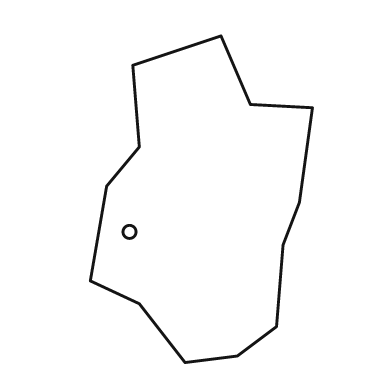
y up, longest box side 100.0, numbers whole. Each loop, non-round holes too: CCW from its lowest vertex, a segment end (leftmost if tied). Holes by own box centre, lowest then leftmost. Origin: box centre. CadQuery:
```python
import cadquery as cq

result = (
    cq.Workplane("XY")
    .moveTo(-5.0, -50.0)
    .lineTo(11.0, -48.0)
    .lineTo(23.0, -39.0)
    .lineTo(25.0, -14.0)
    .lineTo(30.0, -1.0)
    .lineTo(34.0, 28.0)
    .lineTo(15.0, 29.0)
    .lineTo(6.0, 50.0)
    .lineTo(-21.0, 41.0)
    .lineTo(-19.0, 16.0)
    .lineTo(-29.0, 4.0)
    .lineTo(-34.0, -25.0)
    .lineTo(-19.0, -32.0)
    .close()
    .moveTo(-22.0, -10.0)
    .circle(2.0)
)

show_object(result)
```